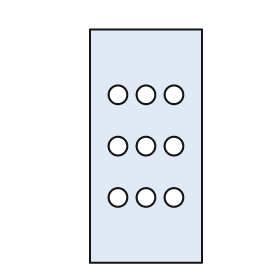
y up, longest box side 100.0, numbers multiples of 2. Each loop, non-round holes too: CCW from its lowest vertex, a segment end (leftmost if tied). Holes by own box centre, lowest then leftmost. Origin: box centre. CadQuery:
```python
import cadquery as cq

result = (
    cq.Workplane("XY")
    .moveTo(-24.0, -50.0)
    .lineTo(24.0, -50.0)
    .lineTo(24.0, 50.0)
    .lineTo(-24.0, 50.0)
    .close()
    .moveTo(-12.0, -22.0)
    .circle(4.0)
    .moveTo(0.0, -22.0)
    .circle(4.0)
    .moveTo(12.0, -22.0)
    .circle(4.0)
    .moveTo(-12.0, 0.0)
    .circle(4.0)
    .moveTo(0.0, 0.0)
    .circle(4.0)
    .moveTo(12.0, 0.0)
    .circle(4.0)
    .moveTo(-12.0, 22.0)
    .circle(4.0)
    .moveTo(0.0, 22.0)
    .circle(4.0)
    .moveTo(12.0, 22.0)
    .circle(4.0)
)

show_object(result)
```